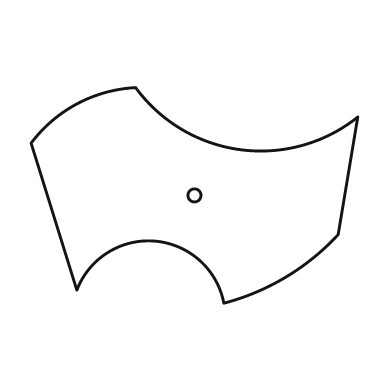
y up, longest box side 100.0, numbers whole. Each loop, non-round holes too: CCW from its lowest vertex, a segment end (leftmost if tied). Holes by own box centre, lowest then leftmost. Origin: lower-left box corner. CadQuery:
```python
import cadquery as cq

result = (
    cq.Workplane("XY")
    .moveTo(59.0, 0.0)
    .threePointArc((78.0, 8.0), (94.0, 21.0))
    .lineTo(100.0, 57.0)
    .threePointArc((64.0, 47.0), (32.0, 66.0))
    .threePointArc((14.0, 61.0), (0.0, 49.0))
    .lineTo(14.0, 4.0)
    .threePointArc((38.0, 19.0), (59.0, 0.0))
    .close()
    .moveTo(50.0, 33.0)
    .circle(2.0)
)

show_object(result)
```